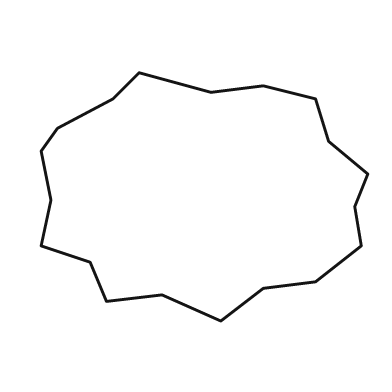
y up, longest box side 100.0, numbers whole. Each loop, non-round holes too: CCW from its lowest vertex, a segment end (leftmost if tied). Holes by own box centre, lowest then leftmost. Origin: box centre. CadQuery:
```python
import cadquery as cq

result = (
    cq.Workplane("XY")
    .moveTo(5.0, -38.0)
    .lineTo(18.0, -28.0)
    .lineTo(34.0, -26.0)
    .lineTo(48.0, -15.0)
    .lineTo(46.0, -3.0)
    .lineTo(50.0, 7.0)
    .lineTo(38.0, 17.0)
    .lineTo(34.0, 30.0)
    .lineTo(18.0, 34.0)
    .lineTo(2.0, 32.0)
    .lineTo(-20.0, 38.0)
    .lineTo(-28.0, 30.0)
    .lineTo(-45.0, 21.0)
    .lineTo(-50.0, 14.0)
    .lineTo(-47.0, -1.0)
    .lineTo(-50.0, -15.0)
    .lineTo(-35.0, -20.0)
    .lineTo(-30.0, -32.0)
    .lineTo(-13.0, -30.0)
    .close()
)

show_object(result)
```